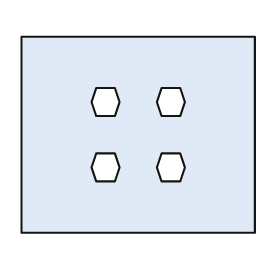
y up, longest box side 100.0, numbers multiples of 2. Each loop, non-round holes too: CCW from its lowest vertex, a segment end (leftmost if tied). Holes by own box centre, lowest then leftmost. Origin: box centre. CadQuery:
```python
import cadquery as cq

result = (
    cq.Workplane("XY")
    .moveTo(-50.0, -42.0)
    .lineTo(50.0, -42.0)
    .lineTo(50.0, 42.0)
    .lineTo(-50.0, 42.0)
    .close()
    .moveTo(-18.0, -20.0)
    .lineTo(-10.0, -20.0)
    .lineTo(-8.0, -14.0)
    .lineTo(-10.0, -8.0)
    .lineTo(-18.0, -8.0)
    .lineTo(-20.0, -14.0)
    .close()
    .moveTo(10.0, -20.0)
    .lineTo(18.0, -20.0)
    .lineTo(20.0, -14.0)
    .lineTo(18.0, -8.0)
    .lineTo(10.0, -8.0)
    .lineTo(8.0, -14.0)
    .close()
    .moveTo(-18.0, 8.0)
    .lineTo(-10.0, 8.0)
    .lineTo(-8.0, 14.0)
    .lineTo(-10.0, 20.0)
    .lineTo(-18.0, 20.0)
    .lineTo(-20.0, 14.0)
    .close()
    .moveTo(10.0, 8.0)
    .lineTo(18.0, 8.0)
    .lineTo(20.0, 14.0)
    .lineTo(18.0, 20.0)
    .lineTo(10.0, 20.0)
    .lineTo(8.0, 14.0)
    .close()
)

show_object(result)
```